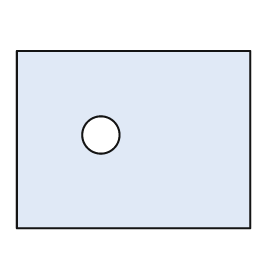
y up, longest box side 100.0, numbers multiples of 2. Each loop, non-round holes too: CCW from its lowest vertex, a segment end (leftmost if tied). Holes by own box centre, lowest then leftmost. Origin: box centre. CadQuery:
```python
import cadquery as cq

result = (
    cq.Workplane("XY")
    .moveTo(-50.0, -38.0)
    .lineTo(50.0, -38.0)
    .lineTo(50.0, 38.0)
    .lineTo(-50.0, 38.0)
    .close()
    .moveTo(-14.0, 2.0)
    .circle(8.0)
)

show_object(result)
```